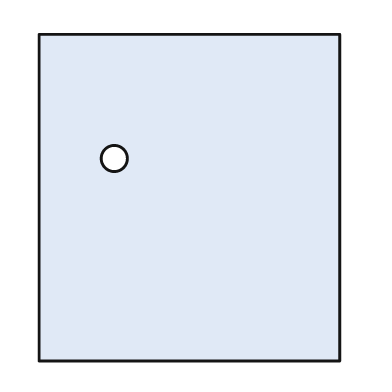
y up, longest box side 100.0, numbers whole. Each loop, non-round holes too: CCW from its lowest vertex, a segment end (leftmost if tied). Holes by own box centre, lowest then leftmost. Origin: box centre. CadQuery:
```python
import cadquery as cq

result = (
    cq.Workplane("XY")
    .moveTo(-46.0, -50.0)
    .lineTo(46.0, -50.0)
    .lineTo(46.0, 50.0)
    .lineTo(-46.0, 50.0)
    .close()
    .moveTo(-23.0, 12.0)
    .circle(4.0)
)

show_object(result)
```